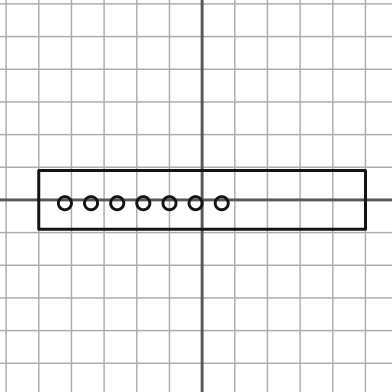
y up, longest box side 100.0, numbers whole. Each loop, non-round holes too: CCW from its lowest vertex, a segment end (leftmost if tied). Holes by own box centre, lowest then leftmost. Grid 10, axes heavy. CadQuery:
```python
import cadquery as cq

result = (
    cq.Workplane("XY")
    .moveTo(-50.0, -9.0)
    .lineTo(50.0, -9.0)
    .lineTo(50.0, 9.0)
    .lineTo(-50.0, 9.0)
    .close()
    .moveTo(-42.0, -1.0)
    .circle(2.0)
    .moveTo(-34.0, -1.0)
    .circle(2.0)
    .moveTo(-26.0, -1.0)
    .circle(2.0)
    .moveTo(-18.0, -1.0)
    .circle(2.0)
    .moveTo(-10.0, -1.0)
    .circle(2.0)
    .moveTo(-2.0, -1.0)
    .circle(2.0)
    .moveTo(6.0, -1.0)
    .circle(2.0)
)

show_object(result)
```